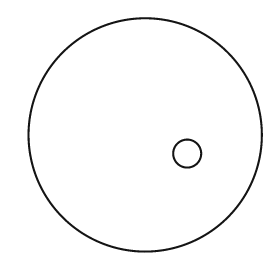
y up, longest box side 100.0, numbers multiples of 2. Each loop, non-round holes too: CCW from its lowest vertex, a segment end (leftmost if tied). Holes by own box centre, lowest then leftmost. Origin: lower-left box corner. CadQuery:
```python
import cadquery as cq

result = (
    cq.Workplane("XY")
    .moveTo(50.0, 50.0)
    .circle(50.0)
    .moveTo(68.0, 42.0)
    .circle(6.0)
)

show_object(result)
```